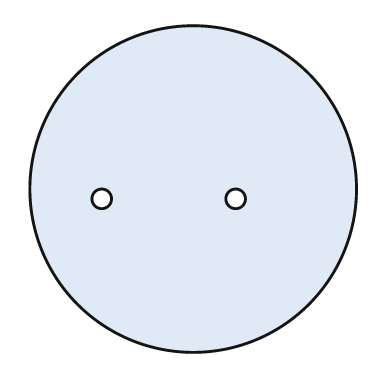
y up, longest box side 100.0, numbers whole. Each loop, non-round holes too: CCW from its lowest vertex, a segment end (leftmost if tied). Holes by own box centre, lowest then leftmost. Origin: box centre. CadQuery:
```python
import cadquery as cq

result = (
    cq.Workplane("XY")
    .moveTo(0.0, 0.0)
    .circle(50.0)
    .moveTo(-28.0, -3.0)
    .circle(3.0)
    .moveTo(13.0, -3.0)
    .circle(3.0)
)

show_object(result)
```